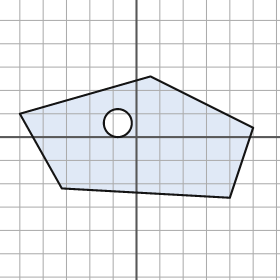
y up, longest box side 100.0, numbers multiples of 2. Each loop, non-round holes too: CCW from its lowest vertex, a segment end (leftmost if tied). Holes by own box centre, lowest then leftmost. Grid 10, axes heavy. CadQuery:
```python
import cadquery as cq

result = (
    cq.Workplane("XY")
    .moveTo(40.0, -26.0)
    .lineTo(50.0, 4.0)
    .lineTo(6.0, 26.0)
    .lineTo(-50.0, 10.0)
    .lineTo(-32.0, -22.0)
    .close()
    .moveTo(-8.0, 6.0)
    .circle(6.0)
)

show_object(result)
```